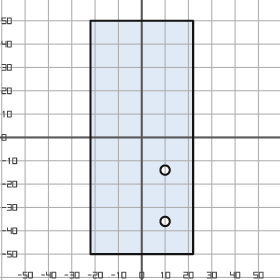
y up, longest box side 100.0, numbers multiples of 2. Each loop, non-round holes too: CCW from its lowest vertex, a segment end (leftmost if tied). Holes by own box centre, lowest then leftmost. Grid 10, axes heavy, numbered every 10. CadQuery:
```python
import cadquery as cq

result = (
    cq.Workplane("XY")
    .moveTo(-22.0, -50.0)
    .lineTo(22.0, -50.0)
    .lineTo(22.0, 50.0)
    .lineTo(-22.0, 50.0)
    .close()
    .moveTo(10.0, -36.0)
    .circle(2.0)
    .moveTo(10.0, -14.0)
    .circle(2.0)
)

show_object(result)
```